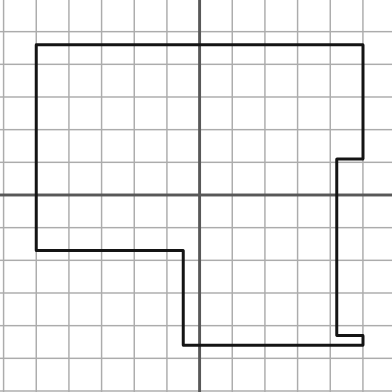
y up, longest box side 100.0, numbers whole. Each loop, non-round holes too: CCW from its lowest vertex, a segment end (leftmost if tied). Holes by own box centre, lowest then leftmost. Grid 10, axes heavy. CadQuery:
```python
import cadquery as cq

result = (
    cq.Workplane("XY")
    .moveTo(-5.0, -46.0)
    .lineTo(50.0, -46.0)
    .lineTo(50.0, -43.0)
    .lineTo(42.0, -43.0)
    .lineTo(42.0, 11.0)
    .lineTo(50.0, 11.0)
    .lineTo(50.0, 46.0)
    .lineTo(-50.0, 46.0)
    .lineTo(-50.0, -17.0)
    .lineTo(-5.0, -17.0)
    .close()
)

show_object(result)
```